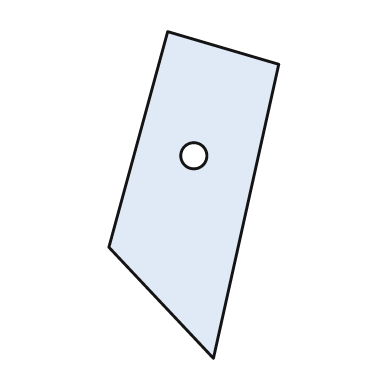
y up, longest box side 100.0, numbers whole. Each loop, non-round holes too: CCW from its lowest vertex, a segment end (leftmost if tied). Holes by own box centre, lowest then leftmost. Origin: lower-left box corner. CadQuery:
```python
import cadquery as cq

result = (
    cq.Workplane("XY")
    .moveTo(32.0, 0.0)
    .lineTo(52.0, 90.0)
    .lineTo(18.0, 100.0)
    .lineTo(0.0, 34.0)
    .close()
    .moveTo(26.0, 62.0)
    .circle(4.0)
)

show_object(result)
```